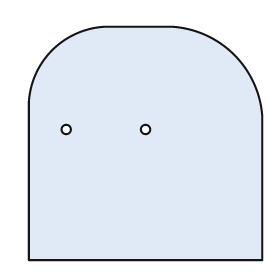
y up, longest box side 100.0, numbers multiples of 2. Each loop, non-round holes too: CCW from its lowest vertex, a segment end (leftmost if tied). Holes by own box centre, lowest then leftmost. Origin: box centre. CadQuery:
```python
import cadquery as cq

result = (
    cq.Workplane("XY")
    .moveTo(-50.0, -50.0)
    .lineTo(50.0, -50.0)
    .lineTo(50.0, 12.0)
    .threePointArc((38.0, 38.0), (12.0, 50.0))
    .lineTo(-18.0, 50.0)
    .threePointArc((-40.0, 40.0), (-50.0, 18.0))
    .close()
    .moveTo(-34.0, 6.0)
    .circle(2.0)
    .moveTo(0.0, 6.0)
    .circle(2.0)
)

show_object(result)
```